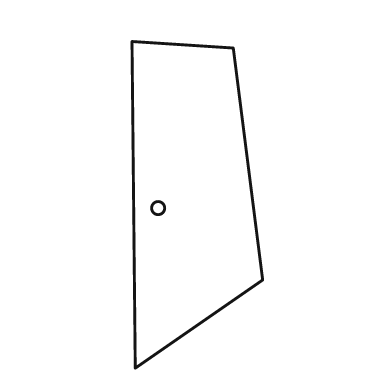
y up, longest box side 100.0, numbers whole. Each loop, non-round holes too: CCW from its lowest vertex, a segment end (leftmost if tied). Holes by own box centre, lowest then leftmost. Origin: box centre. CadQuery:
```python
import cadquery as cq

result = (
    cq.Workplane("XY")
    .moveTo(-19.0, -50.0)
    .lineTo(20.0, -23.0)
    .lineTo(11.0, 48.0)
    .lineTo(-20.0, 50.0)
    .close()
    .moveTo(-12.0, -1.0)
    .circle(2.0)
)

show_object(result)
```